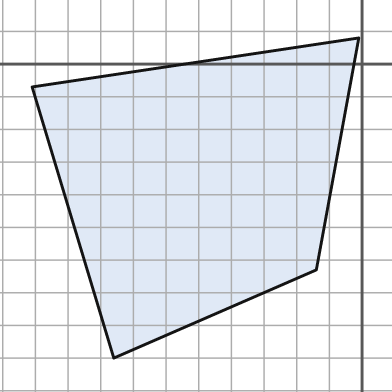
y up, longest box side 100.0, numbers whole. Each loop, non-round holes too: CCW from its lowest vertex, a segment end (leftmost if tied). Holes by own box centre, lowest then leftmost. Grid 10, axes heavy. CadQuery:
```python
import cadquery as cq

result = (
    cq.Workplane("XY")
    .moveTo(-76.0, -90.0)
    .lineTo(-14.0, -63.0)
    .lineTo(-1.0, 8.0)
    .lineTo(-101.0, -7.0)
    .close()
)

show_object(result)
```